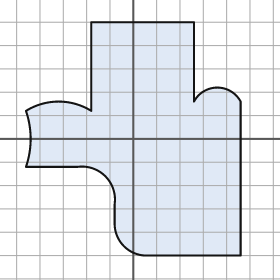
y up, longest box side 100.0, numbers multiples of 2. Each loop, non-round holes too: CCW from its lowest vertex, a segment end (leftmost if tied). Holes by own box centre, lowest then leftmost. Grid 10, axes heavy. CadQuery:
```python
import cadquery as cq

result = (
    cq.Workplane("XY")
    .moveTo(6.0, -50.0)
    .lineTo(46.0, -50.0)
    .lineTo(46.0, 16.0)
    .threePointArc((36.0, 22.0), (26.0, 16.0))
    .lineTo(26.0, 50.0)
    .lineTo(-18.0, 50.0)
    .lineTo(-18.0, 12.0)
    .threePointArc((-32.0, 16.0), (-46.0, 12.0))
    .threePointArc((-44.0, 0.0), (-46.0, -12.0))
    .lineTo(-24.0, -12.0)
    .threePointArc((-12.0, -16.0), (-8.0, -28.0))
    .lineTo(-8.0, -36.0)
    .threePointArc((-4.0, -46.0), (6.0, -50.0))
    .close()
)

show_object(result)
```